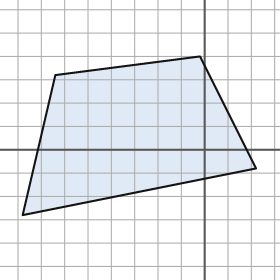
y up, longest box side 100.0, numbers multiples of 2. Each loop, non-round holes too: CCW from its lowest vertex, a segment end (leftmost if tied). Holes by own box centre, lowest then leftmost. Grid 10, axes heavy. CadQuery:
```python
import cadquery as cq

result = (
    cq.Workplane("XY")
    .moveTo(-78.0, -28.0)
    .lineTo(22.0, -8.0)
    .lineTo(-2.0, 40.0)
    .lineTo(-64.0, 32.0)
    .close()
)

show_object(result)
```